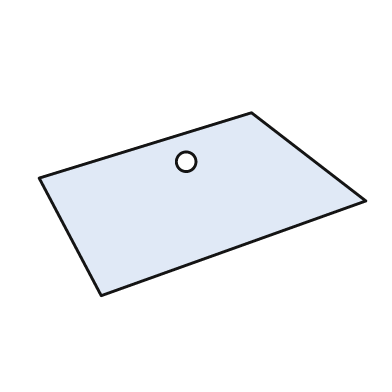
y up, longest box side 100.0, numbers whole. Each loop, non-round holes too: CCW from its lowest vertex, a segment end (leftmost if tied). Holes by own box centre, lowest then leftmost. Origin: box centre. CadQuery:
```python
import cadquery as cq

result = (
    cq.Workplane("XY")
    .moveTo(-31.0, -28.0)
    .lineTo(50.0, 1.0)
    .lineTo(15.0, 28.0)
    .lineTo(-50.0, 8.0)
    .close()
    .moveTo(-5.0, 13.0)
    .circle(3.0)
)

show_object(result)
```